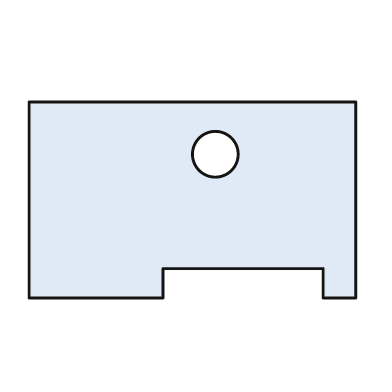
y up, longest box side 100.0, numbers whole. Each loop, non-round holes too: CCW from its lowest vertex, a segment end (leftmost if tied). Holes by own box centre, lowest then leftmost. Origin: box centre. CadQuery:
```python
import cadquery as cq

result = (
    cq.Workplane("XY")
    .moveTo(-50.0, -30.0)
    .lineTo(-9.0, -30.0)
    .lineTo(-9.0, -21.0)
    .lineTo(40.0, -21.0)
    .lineTo(40.0, -30.0)
    .lineTo(50.0, -30.0)
    .lineTo(50.0, 30.0)
    .lineTo(-50.0, 30.0)
    .close()
    .moveTo(7.0, 14.0)
    .circle(7.0)
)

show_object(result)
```